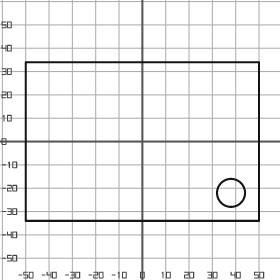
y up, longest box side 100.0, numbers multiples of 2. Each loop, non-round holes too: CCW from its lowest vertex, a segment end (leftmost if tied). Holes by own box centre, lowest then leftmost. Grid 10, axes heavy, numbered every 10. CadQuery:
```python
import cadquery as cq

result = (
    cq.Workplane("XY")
    .moveTo(-50.0, -34.0)
    .lineTo(50.0, -34.0)
    .lineTo(50.0, 34.0)
    .lineTo(-50.0, 34.0)
    .close()
    .moveTo(38.0, -22.0)
    .circle(6.0)
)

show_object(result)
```